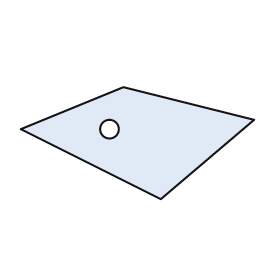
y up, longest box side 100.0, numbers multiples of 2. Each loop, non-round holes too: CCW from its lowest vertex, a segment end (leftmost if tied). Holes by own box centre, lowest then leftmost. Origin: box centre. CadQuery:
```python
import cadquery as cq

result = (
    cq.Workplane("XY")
    .moveTo(10.0, -24.0)
    .lineTo(50.0, 10.0)
    .lineTo(-6.0, 24.0)
    .lineTo(-50.0, 6.0)
    .close()
    .moveTo(-12.0, 6.0)
    .circle(4.0)
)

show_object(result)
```